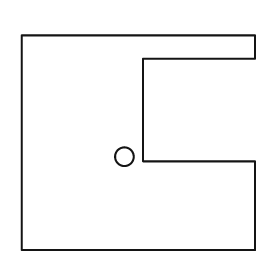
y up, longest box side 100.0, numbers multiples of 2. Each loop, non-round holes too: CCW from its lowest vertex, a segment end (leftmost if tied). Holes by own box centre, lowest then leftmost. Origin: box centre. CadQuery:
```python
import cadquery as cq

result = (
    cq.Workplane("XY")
    .moveTo(-50.0, -46.0)
    .lineTo(50.0, -46.0)
    .lineTo(50.0, -8.0)
    .lineTo(2.0, -8.0)
    .lineTo(2.0, 36.0)
    .lineTo(50.0, 36.0)
    .lineTo(50.0, 46.0)
    .lineTo(-50.0, 46.0)
    .close()
    .moveTo(-6.0, -6.0)
    .circle(4.0)
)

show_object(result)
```